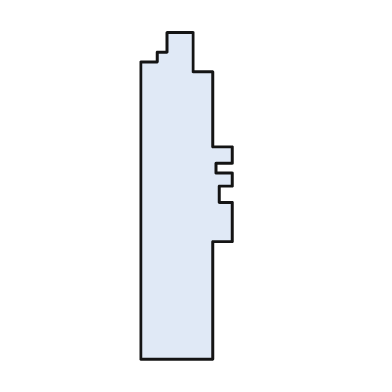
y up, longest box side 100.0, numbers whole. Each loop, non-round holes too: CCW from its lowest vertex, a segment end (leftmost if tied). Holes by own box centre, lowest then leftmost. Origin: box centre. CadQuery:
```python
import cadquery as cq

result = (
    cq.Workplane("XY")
    .moveTo(-14.0, -50.0)
    .lineTo(8.0, -50.0)
    .lineTo(8.0, -14.0)
    .lineTo(14.0, -14.0)
    .lineTo(14.0, -2.0)
    .lineTo(10.0, -2.0)
    .lineTo(10.0, 3.0)
    .lineTo(14.0, 3.0)
    .lineTo(14.0, 7.0)
    .lineTo(9.0, 7.0)
    .lineTo(9.0, 10.0)
    .lineTo(14.0, 10.0)
    .lineTo(14.0, 15.0)
    .lineTo(8.0, 15.0)
    .lineTo(8.0, 38.0)
    .lineTo(2.0, 38.0)
    .lineTo(2.0, 50.0)
    .lineTo(-6.0, 50.0)
    .lineTo(-6.0, 44.0)
    .lineTo(-9.0, 44.0)
    .lineTo(-9.0, 41.0)
    .lineTo(-14.0, 41.0)
    .close()
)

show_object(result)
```